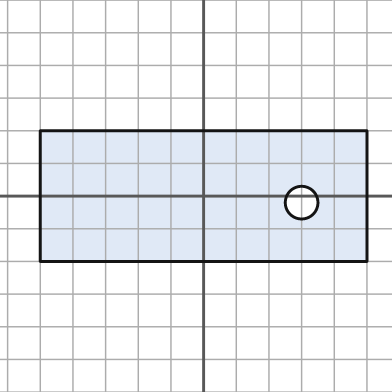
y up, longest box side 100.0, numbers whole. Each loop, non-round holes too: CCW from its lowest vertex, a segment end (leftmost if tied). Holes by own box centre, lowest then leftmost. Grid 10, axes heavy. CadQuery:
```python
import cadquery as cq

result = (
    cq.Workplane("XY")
    .moveTo(-50.0, -20.0)
    .lineTo(50.0, -20.0)
    .lineTo(50.0, 20.0)
    .lineTo(-50.0, 20.0)
    .close()
    .moveTo(30.0, -2.0)
    .circle(5.0)
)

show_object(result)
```